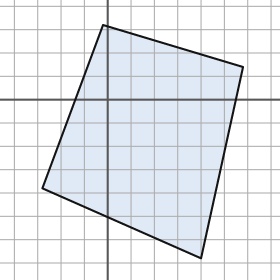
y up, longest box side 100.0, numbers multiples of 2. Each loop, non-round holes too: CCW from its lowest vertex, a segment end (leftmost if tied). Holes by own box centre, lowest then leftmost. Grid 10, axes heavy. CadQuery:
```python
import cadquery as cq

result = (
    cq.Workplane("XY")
    .moveTo(40.0, -68.0)
    .lineTo(58.0, 14.0)
    .lineTo(-2.0, 32.0)
    .lineTo(-28.0, -38.0)
    .close()
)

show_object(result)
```